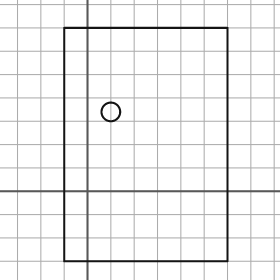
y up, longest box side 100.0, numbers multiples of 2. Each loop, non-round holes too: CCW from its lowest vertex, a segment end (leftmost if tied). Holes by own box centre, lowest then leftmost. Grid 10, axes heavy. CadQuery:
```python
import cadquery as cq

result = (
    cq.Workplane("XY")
    .moveTo(-10.0, -30.0)
    .lineTo(60.0, -30.0)
    .lineTo(60.0, 70.0)
    .lineTo(-10.0, 70.0)
    .close()
    .moveTo(10.0, 34.0)
    .circle(4.0)
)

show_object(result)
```